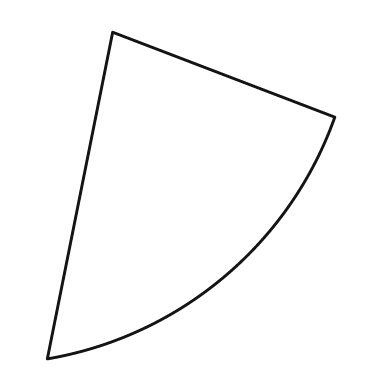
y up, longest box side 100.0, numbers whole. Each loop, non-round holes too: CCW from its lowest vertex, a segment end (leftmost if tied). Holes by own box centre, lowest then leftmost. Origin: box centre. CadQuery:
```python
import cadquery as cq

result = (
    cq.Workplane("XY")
    .moveTo(-44.0, -50.0)
    .threePointArc((10.0, -25.0), (44.0, 24.0))
    .lineTo(-24.0, 50.0)
    .close()
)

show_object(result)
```